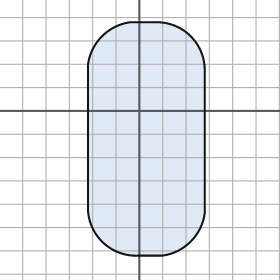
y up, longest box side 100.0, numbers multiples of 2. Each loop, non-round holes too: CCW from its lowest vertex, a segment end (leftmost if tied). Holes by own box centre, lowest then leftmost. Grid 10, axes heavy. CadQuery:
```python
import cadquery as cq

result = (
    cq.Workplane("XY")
    .moveTo(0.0, -62.0)
    .lineTo(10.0, -62.0)
    .threePointArc((22.0, -56.0), (28.0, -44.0))
    .lineTo(28.0, 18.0)
    .threePointArc((22.0, 32.0), (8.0, 38.0))
    .lineTo(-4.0, 38.0)
    .threePointArc((-16.0, 32.0), (-22.0, 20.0))
    .lineTo(-22.0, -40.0)
    .threePointArc((-16.0, -56.0), (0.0, -62.0))
    .close()
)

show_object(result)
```